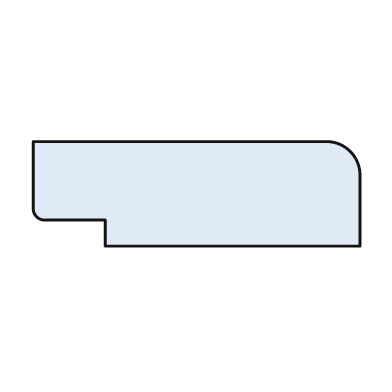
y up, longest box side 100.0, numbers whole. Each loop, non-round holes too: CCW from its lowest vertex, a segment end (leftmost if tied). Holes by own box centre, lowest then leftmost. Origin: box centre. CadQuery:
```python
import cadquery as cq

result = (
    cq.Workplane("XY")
    .moveTo(-28.0, -16.0)
    .lineTo(50.0, -16.0)
    .lineTo(50.0, 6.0)
    .threePointArc((47.0, 13.0), (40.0, 16.0))
    .lineTo(-50.0, 16.0)
    .lineTo(-50.0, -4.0)
    .threePointArc((-49.0, -7.0), (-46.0, -8.0))
    .lineTo(-28.0, -8.0)
    .close()
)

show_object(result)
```